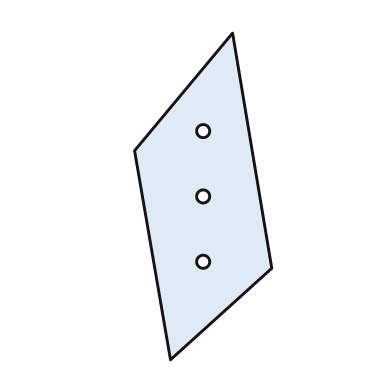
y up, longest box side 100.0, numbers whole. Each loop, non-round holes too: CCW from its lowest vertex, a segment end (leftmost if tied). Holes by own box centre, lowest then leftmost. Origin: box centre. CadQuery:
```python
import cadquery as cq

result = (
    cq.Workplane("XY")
    .moveTo(-10.0, -50.0)
    .lineTo(21.0, -22.0)
    .lineTo(9.0, 50.0)
    .lineTo(-21.0, 14.0)
    .close()
    .moveTo(0.0, -20.0)
    .circle(2.0)
    .moveTo(0.0, 0.0)
    .circle(2.0)
    .moveTo(0.0, 20.0)
    .circle(2.0)
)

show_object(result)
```